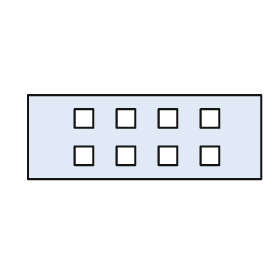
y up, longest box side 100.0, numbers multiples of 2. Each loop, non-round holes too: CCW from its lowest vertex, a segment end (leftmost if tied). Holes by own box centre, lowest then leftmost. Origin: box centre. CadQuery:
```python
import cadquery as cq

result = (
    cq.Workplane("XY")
    .moveTo(-50.0, -18.0)
    .lineTo(50.0, -18.0)
    .lineTo(50.0, 18.0)
    .lineTo(-50.0, 18.0)
    .close()
    .moveTo(-30.0, -12.0)
    .lineTo(-22.0, -12.0)
    .lineTo(-22.0, -4.0)
    .lineTo(-30.0, -4.0)
    .close()
    .moveTo(-12.0, -12.0)
    .lineTo(-4.0, -12.0)
    .lineTo(-4.0, -4.0)
    .lineTo(-12.0, -4.0)
    .close()
    .moveTo(6.0, -12.0)
    .lineTo(14.0, -12.0)
    .lineTo(14.0, -4.0)
    .lineTo(6.0, -4.0)
    .close()
    .moveTo(24.0, -12.0)
    .lineTo(32.0, -12.0)
    .lineTo(32.0, -4.0)
    .lineTo(24.0, -4.0)
    .close()
    .moveTo(-30.0, 4.0)
    .lineTo(-22.0, 4.0)
    .lineTo(-22.0, 12.0)
    .lineTo(-30.0, 12.0)
    .close()
    .moveTo(-12.0, 4.0)
    .lineTo(-4.0, 4.0)
    .lineTo(-4.0, 12.0)
    .lineTo(-12.0, 12.0)
    .close()
    .moveTo(6.0, 4.0)
    .lineTo(14.0, 4.0)
    .lineTo(14.0, 12.0)
    .lineTo(6.0, 12.0)
    .close()
    .moveTo(24.0, 4.0)
    .lineTo(32.0, 4.0)
    .lineTo(32.0, 12.0)
    .lineTo(24.0, 12.0)
    .close()
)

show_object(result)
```